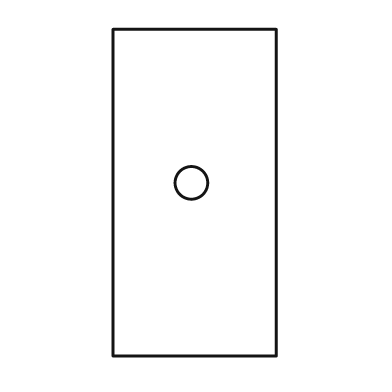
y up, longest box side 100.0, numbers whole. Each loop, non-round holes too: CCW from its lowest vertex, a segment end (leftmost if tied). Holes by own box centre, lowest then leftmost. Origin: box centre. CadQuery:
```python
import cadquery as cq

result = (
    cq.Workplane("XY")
    .moveTo(-25.0, -50.0)
    .lineTo(25.0, -50.0)
    .lineTo(25.0, 50.0)
    .lineTo(-25.0, 50.0)
    .close()
    .moveTo(-1.0, 3.0)
    .circle(5.0)
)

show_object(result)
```